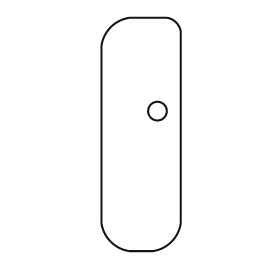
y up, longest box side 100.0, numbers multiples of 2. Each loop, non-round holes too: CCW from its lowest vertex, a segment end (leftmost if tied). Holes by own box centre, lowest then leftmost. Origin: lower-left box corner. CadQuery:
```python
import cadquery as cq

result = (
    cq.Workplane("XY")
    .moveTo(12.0, 0.0)
    .lineTo(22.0, 0.0)
    .threePointArc((30.0, 4.0), (34.0, 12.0))
    .lineTo(34.0, 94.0)
    .threePointArc((32.0, 98.0), (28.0, 100.0))
    .lineTo(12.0, 100.0)
    .threePointArc((4.0, 96.0), (0.0, 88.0))
    .lineTo(0.0, 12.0)
    .threePointArc((4.0, 4.0), (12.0, 0.0))
    .close()
    .moveTo(24.0, 60.0)
    .circle(4.0)
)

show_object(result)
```